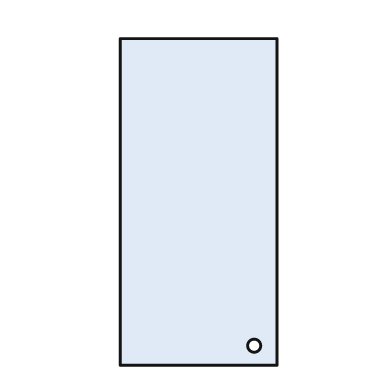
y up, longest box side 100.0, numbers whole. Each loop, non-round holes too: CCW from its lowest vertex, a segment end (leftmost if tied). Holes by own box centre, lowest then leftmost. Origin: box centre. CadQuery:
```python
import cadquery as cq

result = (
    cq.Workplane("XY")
    .moveTo(-24.0, -50.0)
    .lineTo(24.0, -50.0)
    .lineTo(24.0, 50.0)
    .lineTo(-24.0, 50.0)
    .close()
    .moveTo(17.0, -44.0)
    .circle(2.0)
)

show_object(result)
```